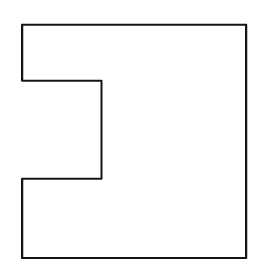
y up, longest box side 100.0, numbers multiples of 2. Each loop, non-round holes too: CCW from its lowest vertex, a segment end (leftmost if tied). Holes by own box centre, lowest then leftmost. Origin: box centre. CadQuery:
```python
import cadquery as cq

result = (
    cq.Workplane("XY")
    .moveTo(-48.0, -50.0)
    .lineTo(48.0, -50.0)
    .lineTo(48.0, 50.0)
    .lineTo(-48.0, 50.0)
    .lineTo(-48.0, 26.0)
    .lineTo(-14.0, 26.0)
    .lineTo(-14.0, -16.0)
    .lineTo(-48.0, -16.0)
    .close()
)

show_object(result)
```